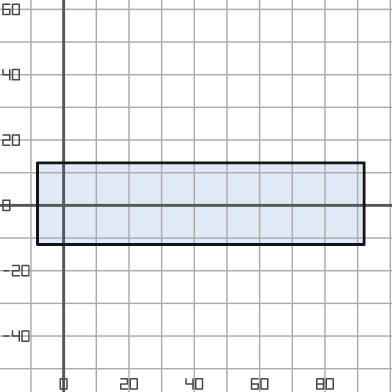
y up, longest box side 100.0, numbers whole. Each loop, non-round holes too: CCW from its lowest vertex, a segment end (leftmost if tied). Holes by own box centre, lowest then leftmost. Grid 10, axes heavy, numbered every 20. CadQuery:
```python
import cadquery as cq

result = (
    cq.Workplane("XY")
    .moveTo(-8.0, -12.0)
    .lineTo(92.0, -12.0)
    .lineTo(92.0, 13.0)
    .lineTo(-8.0, 13.0)
    .close()
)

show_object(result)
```